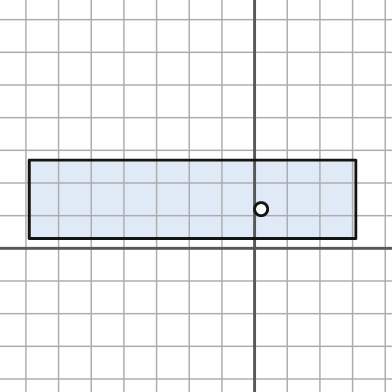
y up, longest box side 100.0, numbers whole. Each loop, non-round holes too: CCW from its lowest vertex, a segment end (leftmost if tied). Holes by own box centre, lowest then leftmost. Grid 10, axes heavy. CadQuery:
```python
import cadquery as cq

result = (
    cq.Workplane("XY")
    .moveTo(-69.0, 3.0)
    .lineTo(31.0, 3.0)
    .lineTo(31.0, 27.0)
    .lineTo(-69.0, 27.0)
    .close()
    .moveTo(2.0, 12.0)
    .circle(2.0)
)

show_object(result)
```